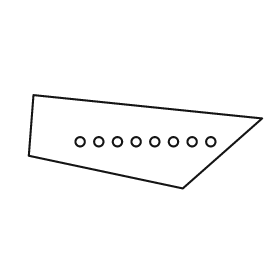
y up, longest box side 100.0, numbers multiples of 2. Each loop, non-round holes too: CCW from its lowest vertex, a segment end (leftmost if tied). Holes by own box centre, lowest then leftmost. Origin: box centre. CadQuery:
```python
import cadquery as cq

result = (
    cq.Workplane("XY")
    .moveTo(16.0, -20.0)
    .lineTo(50.0, 10.0)
    .lineTo(-48.0, 20.0)
    .lineTo(-50.0, -6.0)
    .close()
    .moveTo(-28.0, 0.0)
    .circle(2.0)
    .moveTo(-20.0, 0.0)
    .circle(2.0)
    .moveTo(-12.0, 0.0)
    .circle(2.0)
    .moveTo(-4.0, 0.0)
    .circle(2.0)
    .moveTo(4.0, 0.0)
    .circle(2.0)
    .moveTo(12.0, 0.0)
    .circle(2.0)
    .moveTo(20.0, 0.0)
    .circle(2.0)
    .moveTo(28.0, 0.0)
    .circle(2.0)
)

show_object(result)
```